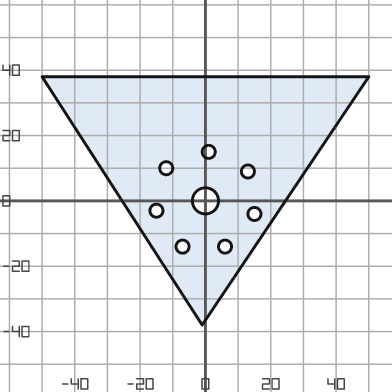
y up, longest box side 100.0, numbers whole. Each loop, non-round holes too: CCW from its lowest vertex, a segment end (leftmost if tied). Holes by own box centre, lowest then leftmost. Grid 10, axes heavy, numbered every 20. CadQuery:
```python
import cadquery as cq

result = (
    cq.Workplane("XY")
    .moveTo(-1.0, -38.0)
    .lineTo(50.0, 38.0)
    .lineTo(-50.0, 38.0)
    .close()
    .moveTo(-7.0, -14.0)
    .circle(2.0)
    .moveTo(6.0, -14.0)
    .circle(2.0)
    .moveTo(15.0, -4.0)
    .circle(2.0)
    .moveTo(-15.0, -3.0)
    .circle(2.0)
    .moveTo(0.0, 0.0)
    .circle(4.0)
    .moveTo(13.0, 9.0)
    .circle(2.0)
    .moveTo(-12.0, 10.0)
    .circle(2.0)
    .moveTo(1.0, 15.0)
    .circle(2.0)
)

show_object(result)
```